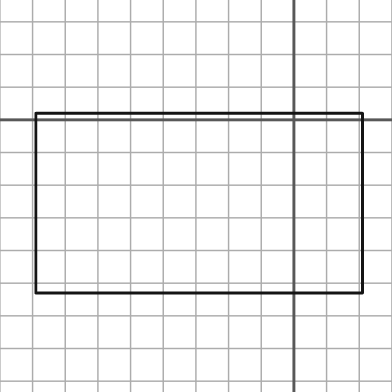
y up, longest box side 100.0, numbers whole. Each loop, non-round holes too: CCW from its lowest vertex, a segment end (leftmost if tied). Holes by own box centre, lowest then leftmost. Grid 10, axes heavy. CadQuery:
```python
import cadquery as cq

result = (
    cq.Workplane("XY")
    .moveTo(-79.0, -53.0)
    .lineTo(21.0, -53.0)
    .lineTo(21.0, 2.0)
    .lineTo(-79.0, 2.0)
    .close()
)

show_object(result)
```